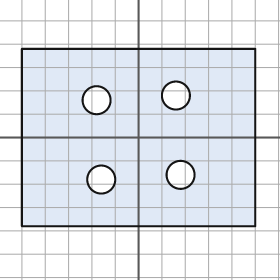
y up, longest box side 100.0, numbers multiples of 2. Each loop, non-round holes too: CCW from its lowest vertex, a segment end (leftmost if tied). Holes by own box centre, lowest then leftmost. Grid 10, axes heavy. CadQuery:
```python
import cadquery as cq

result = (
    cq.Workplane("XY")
    .moveTo(-50.0, -38.0)
    .lineTo(50.0, -38.0)
    .lineTo(50.0, 38.0)
    .lineTo(-50.0, 38.0)
    .close()
    .moveTo(-16.0, -18.0)
    .circle(6.0)
    .moveTo(18.0, -16.0)
    .circle(6.0)
    .moveTo(-18.0, 16.0)
    .circle(6.0)
    .moveTo(16.0, 18.0)
    .circle(6.0)
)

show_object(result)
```